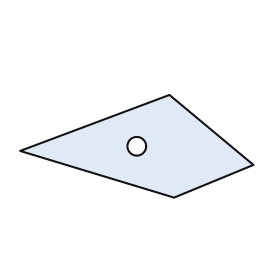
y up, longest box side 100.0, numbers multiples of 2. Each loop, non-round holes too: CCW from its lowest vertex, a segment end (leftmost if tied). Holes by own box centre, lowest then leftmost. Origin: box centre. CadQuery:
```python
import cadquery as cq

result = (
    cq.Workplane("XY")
    .moveTo(16.0, -22.0)
    .lineTo(50.0, -8.0)
    .lineTo(14.0, 22.0)
    .lineTo(-50.0, -2.0)
    .close()
    .moveTo(0.0, 0.0)
    .circle(4.0)
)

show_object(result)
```